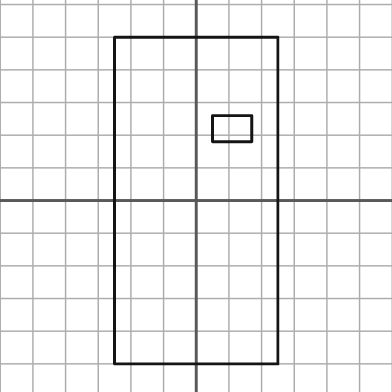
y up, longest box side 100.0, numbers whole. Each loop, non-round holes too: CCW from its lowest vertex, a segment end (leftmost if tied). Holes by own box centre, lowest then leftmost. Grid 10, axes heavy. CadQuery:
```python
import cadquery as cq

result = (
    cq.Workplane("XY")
    .moveTo(-25.0, -50.0)
    .lineTo(25.0, -50.0)
    .lineTo(25.0, 50.0)
    .lineTo(-25.0, 50.0)
    .close()
    .moveTo(5.0, 18.0)
    .lineTo(17.0, 18.0)
    .lineTo(17.0, 26.0)
    .lineTo(5.0, 26.0)
    .close()
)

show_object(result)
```